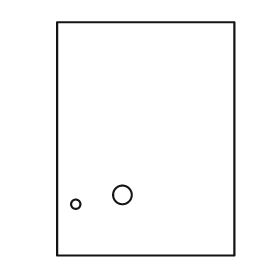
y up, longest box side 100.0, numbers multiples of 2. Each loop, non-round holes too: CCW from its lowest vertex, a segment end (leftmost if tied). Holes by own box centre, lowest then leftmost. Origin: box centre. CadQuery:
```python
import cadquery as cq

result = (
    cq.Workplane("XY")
    .moveTo(-38.0, -50.0)
    .lineTo(38.0, -50.0)
    .lineTo(38.0, 50.0)
    .lineTo(-38.0, 50.0)
    .close()
    .moveTo(-30.0, -28.0)
    .circle(2.0)
    .moveTo(-10.0, -24.0)
    .circle(4.0)
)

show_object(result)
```